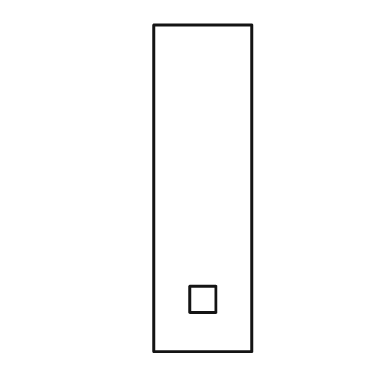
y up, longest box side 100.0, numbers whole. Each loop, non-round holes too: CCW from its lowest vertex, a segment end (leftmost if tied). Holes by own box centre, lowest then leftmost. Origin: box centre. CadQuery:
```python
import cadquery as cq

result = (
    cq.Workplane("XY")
    .moveTo(-15.0, -50.0)
    .lineTo(15.0, -50.0)
    .lineTo(15.0, 50.0)
    .lineTo(-15.0, 50.0)
    .close()
    .moveTo(-4.0, -38.0)
    .lineTo(4.0, -38.0)
    .lineTo(4.0, -30.0)
    .lineTo(-4.0, -30.0)
    .close()
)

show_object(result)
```